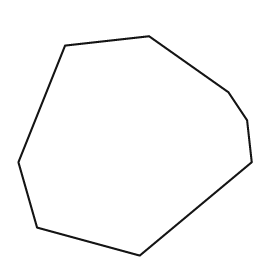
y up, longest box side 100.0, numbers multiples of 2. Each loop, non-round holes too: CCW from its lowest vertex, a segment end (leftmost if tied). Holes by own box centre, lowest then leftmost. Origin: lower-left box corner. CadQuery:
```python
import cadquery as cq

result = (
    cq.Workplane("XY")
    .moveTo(52.0, 0.0)
    .lineTo(100.0, 40.0)
    .lineTo(98.0, 58.0)
    .lineTo(90.0, 70.0)
    .lineTo(56.0, 94.0)
    .lineTo(20.0, 90.0)
    .lineTo(0.0, 40.0)
    .lineTo(8.0, 12.0)
    .close()
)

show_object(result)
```